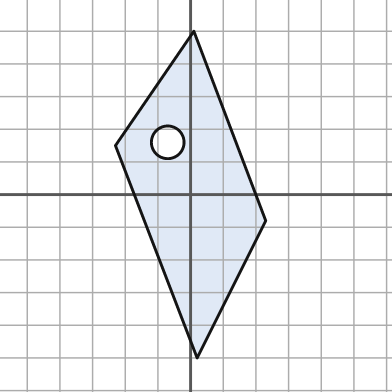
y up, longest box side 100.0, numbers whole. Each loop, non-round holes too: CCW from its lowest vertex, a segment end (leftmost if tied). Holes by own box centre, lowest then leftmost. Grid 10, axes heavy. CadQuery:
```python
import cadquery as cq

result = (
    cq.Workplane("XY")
    .moveTo(2.0, -50.0)
    .lineTo(23.0, -8.0)
    .lineTo(1.0, 50.0)
    .lineTo(-23.0, 15.0)
    .close()
    .moveTo(-7.0, 16.0)
    .circle(5.0)
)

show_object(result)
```